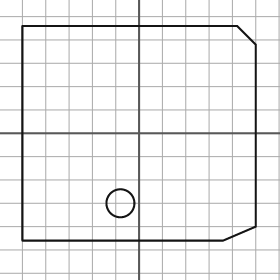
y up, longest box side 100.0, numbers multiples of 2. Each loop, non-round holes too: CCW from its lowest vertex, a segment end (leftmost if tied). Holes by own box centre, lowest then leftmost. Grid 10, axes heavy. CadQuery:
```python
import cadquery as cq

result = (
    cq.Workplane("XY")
    .moveTo(-50.0, -46.0)
    .lineTo(36.0, -46.0)
    .lineTo(50.0, -40.0)
    .lineTo(50.0, 38.0)
    .lineTo(42.0, 46.0)
    .lineTo(-50.0, 46.0)
    .close()
    .moveTo(-8.0, -30.0)
    .circle(6.0)
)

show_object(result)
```